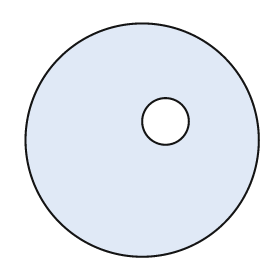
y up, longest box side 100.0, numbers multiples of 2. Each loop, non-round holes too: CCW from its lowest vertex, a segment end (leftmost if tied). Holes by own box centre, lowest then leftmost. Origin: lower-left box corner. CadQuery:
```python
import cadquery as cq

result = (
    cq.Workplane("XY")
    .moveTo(50.0, 50.0)
    .circle(50.0)
    .moveTo(60.0, 58.0)
    .circle(10.0)
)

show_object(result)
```